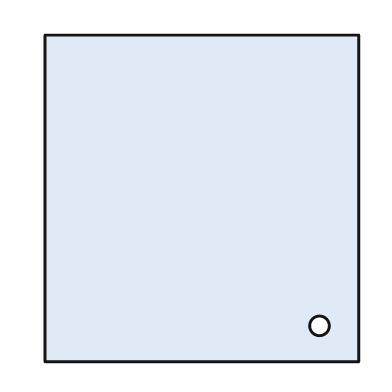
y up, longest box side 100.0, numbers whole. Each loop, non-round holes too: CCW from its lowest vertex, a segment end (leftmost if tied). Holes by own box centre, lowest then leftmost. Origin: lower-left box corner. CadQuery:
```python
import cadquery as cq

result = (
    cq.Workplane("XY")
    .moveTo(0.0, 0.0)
    .lineTo(96.0, 0.0)
    .lineTo(96.0, 100.0)
    .lineTo(0.0, 100.0)
    .close()
    .moveTo(84.0, 11.0)
    .circle(3.0)
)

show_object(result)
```